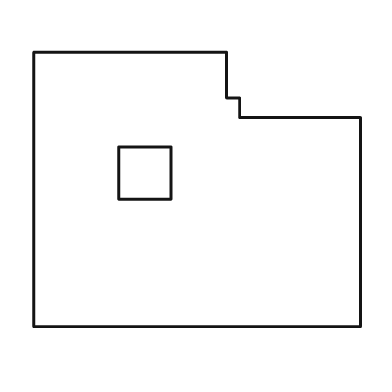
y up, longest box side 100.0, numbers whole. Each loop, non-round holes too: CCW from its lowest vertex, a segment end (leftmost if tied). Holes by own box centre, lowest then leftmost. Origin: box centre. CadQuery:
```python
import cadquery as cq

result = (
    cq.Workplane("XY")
    .moveTo(-50.0, -42.0)
    .lineTo(50.0, -42.0)
    .lineTo(50.0, 22.0)
    .lineTo(13.0, 22.0)
    .lineTo(13.0, 28.0)
    .lineTo(9.0, 28.0)
    .lineTo(9.0, 42.0)
    .lineTo(-50.0, 42.0)
    .close()
    .moveTo(-24.0, -3.0)
    .lineTo(-8.0, -3.0)
    .lineTo(-8.0, 13.0)
    .lineTo(-24.0, 13.0)
    .close()
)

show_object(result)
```